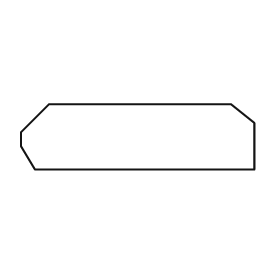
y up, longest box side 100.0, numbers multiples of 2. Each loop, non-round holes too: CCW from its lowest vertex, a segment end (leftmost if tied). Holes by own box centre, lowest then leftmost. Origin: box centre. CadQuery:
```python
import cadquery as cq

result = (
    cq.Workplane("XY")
    .moveTo(-44.0, -14.0)
    .lineTo(50.0, -14.0)
    .lineTo(50.0, 6.0)
    .lineTo(40.0, 14.0)
    .lineTo(-38.0, 14.0)
    .lineTo(-50.0, 2.0)
    .lineTo(-50.0, -4.0)
    .close()
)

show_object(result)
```